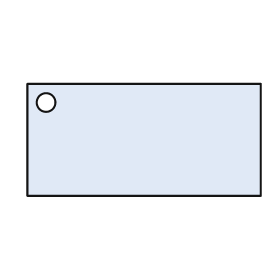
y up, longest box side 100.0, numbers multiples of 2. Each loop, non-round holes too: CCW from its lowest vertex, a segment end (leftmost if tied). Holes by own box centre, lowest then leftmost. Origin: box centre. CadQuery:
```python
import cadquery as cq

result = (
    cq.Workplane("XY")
    .moveTo(-50.0, -24.0)
    .lineTo(50.0, -24.0)
    .lineTo(50.0, 24.0)
    .lineTo(-50.0, 24.0)
    .close()
    .moveTo(-42.0, 16.0)
    .circle(4.0)
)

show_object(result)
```